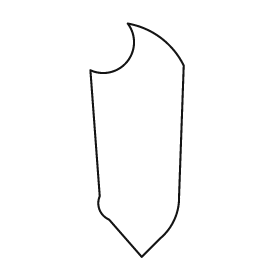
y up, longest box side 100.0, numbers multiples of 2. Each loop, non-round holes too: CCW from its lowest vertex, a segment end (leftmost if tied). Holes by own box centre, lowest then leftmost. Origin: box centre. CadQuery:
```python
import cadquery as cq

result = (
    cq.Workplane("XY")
    .moveTo(2.0, -50.0)
    .lineTo(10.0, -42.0)
    .threePointArc((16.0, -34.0), (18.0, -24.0))
    .lineTo(20.0, 32.0)
    .threePointArc((10.0, 44.0), (-4.0, 50.0))
    .threePointArc((-4.0, 34.0), (-20.0, 30.0))
    .lineTo(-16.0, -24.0)
    .threePointArc((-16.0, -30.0), (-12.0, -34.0))
    .close()
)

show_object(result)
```